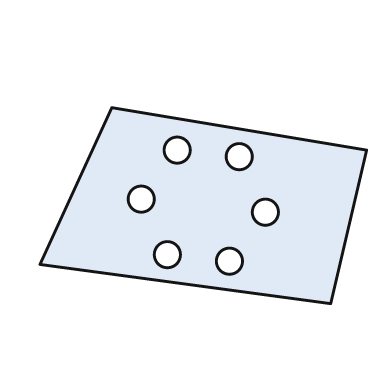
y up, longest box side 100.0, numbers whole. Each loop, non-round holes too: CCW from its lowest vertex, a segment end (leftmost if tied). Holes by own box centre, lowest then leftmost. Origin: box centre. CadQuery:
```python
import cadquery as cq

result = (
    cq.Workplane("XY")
    .moveTo(39.0, -30.0)
    .lineTo(50.0, 17.0)
    .lineTo(-28.0, 30.0)
    .lineTo(-50.0, -18.0)
    .close()
    .moveTo(8.0, -17.0)
    .circle(4.0)
    .moveTo(-11.0, -15.0)
    .circle(4.0)
    .moveTo(19.0, -2.0)
    .circle(4.0)
    .moveTo(-19.0, 2.0)
    .circle(4.0)
    .moveTo(11.0, 15.0)
    .circle(4.0)
    .moveTo(-8.0, 17.0)
    .circle(4.0)
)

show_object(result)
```